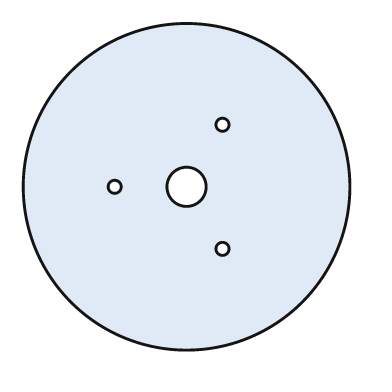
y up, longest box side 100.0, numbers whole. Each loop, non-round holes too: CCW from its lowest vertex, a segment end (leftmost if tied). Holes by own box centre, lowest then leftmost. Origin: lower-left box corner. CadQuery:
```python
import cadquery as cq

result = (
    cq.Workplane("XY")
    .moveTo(50.0, 50.0)
    .circle(50.0)
    .moveTo(61.0, 31.0)
    .circle(2.0)
    .moveTo(28.0, 50.0)
    .circle(2.0)
    .moveTo(50.0, 50.0)
    .circle(6.0)
    .moveTo(61.0, 69.0)
    .circle(2.0)
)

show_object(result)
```